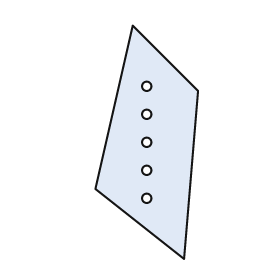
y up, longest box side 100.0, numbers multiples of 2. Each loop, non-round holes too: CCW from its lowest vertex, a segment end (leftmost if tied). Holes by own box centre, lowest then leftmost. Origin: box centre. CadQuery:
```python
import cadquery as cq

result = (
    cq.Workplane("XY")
    .moveTo(16.0, -50.0)
    .lineTo(22.0, 22.0)
    .lineTo(-6.0, 50.0)
    .lineTo(-22.0, -20.0)
    .close()
    .moveTo(0.0, -24.0)
    .circle(2.0)
    .moveTo(0.0, -12.0)
    .circle(2.0)
    .moveTo(0.0, 0.0)
    .circle(2.0)
    .moveTo(0.0, 12.0)
    .circle(2.0)
    .moveTo(0.0, 24.0)
    .circle(2.0)
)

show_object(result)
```